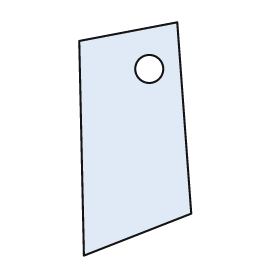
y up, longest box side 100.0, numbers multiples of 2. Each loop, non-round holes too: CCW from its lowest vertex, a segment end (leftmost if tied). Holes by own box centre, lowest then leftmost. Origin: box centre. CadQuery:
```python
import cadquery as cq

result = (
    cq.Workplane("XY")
    .moveTo(-22.0, -50.0)
    .lineTo(24.0, -32.0)
    .lineTo(18.0, 50.0)
    .lineTo(-24.0, 42.0)
    .close()
    .moveTo(6.0, 30.0)
    .circle(6.0)
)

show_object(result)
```